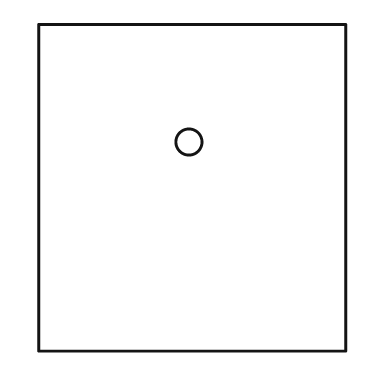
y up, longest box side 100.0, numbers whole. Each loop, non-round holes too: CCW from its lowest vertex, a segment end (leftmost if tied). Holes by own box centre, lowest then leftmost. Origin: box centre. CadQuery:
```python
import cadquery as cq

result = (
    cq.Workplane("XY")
    .moveTo(-47.0, -50.0)
    .lineTo(47.0, -50.0)
    .lineTo(47.0, 50.0)
    .lineTo(-47.0, 50.0)
    .close()
    .moveTo(-1.0, 14.0)
    .circle(4.0)
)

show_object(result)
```